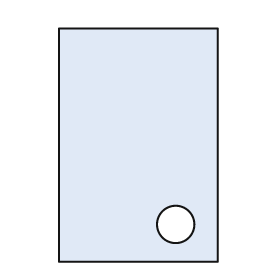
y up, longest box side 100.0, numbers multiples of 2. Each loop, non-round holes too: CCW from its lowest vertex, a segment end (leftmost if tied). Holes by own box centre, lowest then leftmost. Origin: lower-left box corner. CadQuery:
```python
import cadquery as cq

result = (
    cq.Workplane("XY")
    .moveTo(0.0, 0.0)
    .lineTo(68.0, 0.0)
    .lineTo(68.0, 100.0)
    .lineTo(0.0, 100.0)
    .close()
    .moveTo(50.0, 16.0)
    .circle(8.0)
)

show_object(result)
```